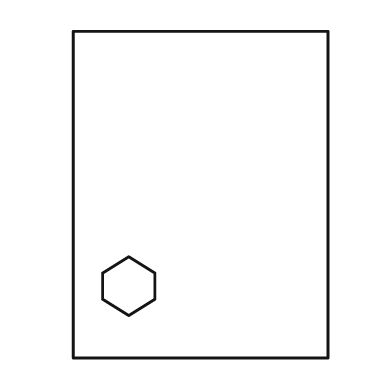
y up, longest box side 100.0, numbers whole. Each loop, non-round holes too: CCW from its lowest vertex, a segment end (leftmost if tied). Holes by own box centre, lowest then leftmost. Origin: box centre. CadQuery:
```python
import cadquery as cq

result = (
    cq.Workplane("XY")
    .moveTo(-39.0, -50.0)
    .lineTo(39.0, -50.0)
    .lineTo(39.0, 50.0)
    .lineTo(-39.0, 50.0)
    .close()
    .moveTo(-22.0, -37.0)
    .lineTo(-14.0, -32.0)
    .lineTo(-14.0, -24.0)
    .lineTo(-22.0, -19.0)
    .lineTo(-30.0, -24.0)
    .lineTo(-30.0, -32.0)
    .close()
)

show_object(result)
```